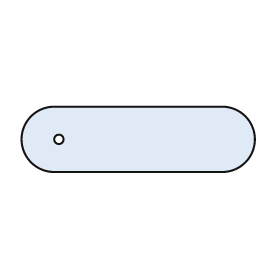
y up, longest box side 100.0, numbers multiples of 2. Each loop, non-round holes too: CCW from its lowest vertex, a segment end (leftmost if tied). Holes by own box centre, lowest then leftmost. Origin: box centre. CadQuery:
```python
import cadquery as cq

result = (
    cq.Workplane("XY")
    .moveTo(-36.0, -14.0)
    .lineTo(36.0, -14.0)
    .threePointArc((50.0, 0.0), (36.0, 14.0))
    .lineTo(-36.0, 14.0)
    .threePointArc((-50.0, 0.0), (-36.0, -14.0))
    .close()
    .moveTo(-34.0, 0.0)
    .circle(2.0)
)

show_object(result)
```